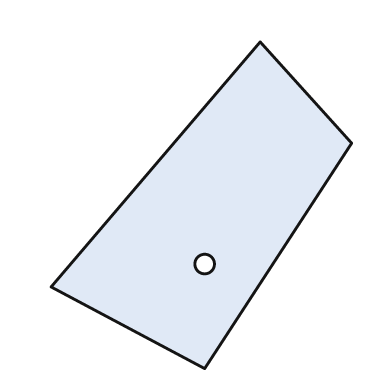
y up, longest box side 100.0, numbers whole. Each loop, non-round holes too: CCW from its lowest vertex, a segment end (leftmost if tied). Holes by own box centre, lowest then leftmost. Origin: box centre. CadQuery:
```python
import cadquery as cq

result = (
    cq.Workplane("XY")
    .moveTo(1.0, -50.0)
    .lineTo(46.0, 19.0)
    .lineTo(18.0, 50.0)
    .lineTo(-46.0, -25.0)
    .close()
    .moveTo(1.0, -18.0)
    .circle(3.0)
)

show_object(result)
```